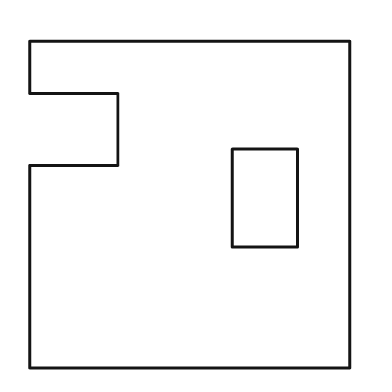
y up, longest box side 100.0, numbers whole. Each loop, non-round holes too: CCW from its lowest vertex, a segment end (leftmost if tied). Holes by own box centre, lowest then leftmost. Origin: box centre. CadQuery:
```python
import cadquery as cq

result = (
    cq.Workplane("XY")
    .moveTo(-49.0, -50.0)
    .lineTo(49.0, -50.0)
    .lineTo(49.0, 50.0)
    .lineTo(-49.0, 50.0)
    .lineTo(-49.0, 34.0)
    .lineTo(-22.0, 34.0)
    .lineTo(-22.0, 12.0)
    .lineTo(-49.0, 12.0)
    .close()
    .moveTo(13.0, -13.0)
    .lineTo(33.0, -13.0)
    .lineTo(33.0, 17.0)
    .lineTo(13.0, 17.0)
    .close()
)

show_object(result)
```